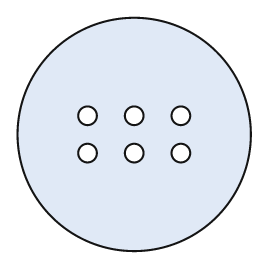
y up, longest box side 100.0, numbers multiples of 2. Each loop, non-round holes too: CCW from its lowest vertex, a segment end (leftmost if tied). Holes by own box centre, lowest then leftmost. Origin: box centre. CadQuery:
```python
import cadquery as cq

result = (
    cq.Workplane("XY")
    .moveTo(0.0, 0.0)
    .circle(50.0)
    .moveTo(-20.0, -8.0)
    .circle(4.0)
    .moveTo(0.0, -8.0)
    .circle(4.0)
    .moveTo(20.0, -8.0)
    .circle(4.0)
    .moveTo(-20.0, 8.0)
    .circle(4.0)
    .moveTo(0.0, 8.0)
    .circle(4.0)
    .moveTo(20.0, 8.0)
    .circle(4.0)
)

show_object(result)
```